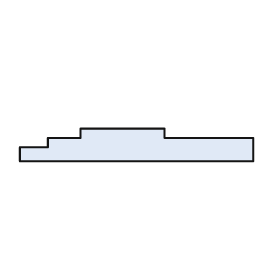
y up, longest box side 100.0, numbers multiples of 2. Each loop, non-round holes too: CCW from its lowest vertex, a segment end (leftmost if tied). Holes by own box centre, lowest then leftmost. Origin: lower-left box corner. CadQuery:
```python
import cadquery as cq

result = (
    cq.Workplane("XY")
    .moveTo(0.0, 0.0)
    .lineTo(100.0, 0.0)
    .lineTo(100.0, 10.0)
    .lineTo(62.0, 10.0)
    .lineTo(62.0, 14.0)
    .lineTo(26.0, 14.0)
    .lineTo(26.0, 10.0)
    .lineTo(12.0, 10.0)
    .lineTo(12.0, 6.0)
    .lineTo(0.0, 6.0)
    .close()
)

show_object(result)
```